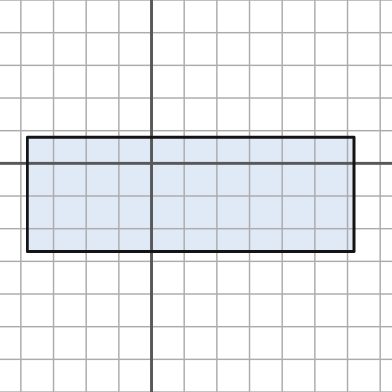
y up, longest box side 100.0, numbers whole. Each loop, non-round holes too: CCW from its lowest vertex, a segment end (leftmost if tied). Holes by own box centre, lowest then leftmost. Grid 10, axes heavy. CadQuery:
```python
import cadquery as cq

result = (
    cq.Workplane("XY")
    .moveTo(-38.0, -27.0)
    .lineTo(62.0, -27.0)
    .lineTo(62.0, 8.0)
    .lineTo(-38.0, 8.0)
    .close()
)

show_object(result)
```